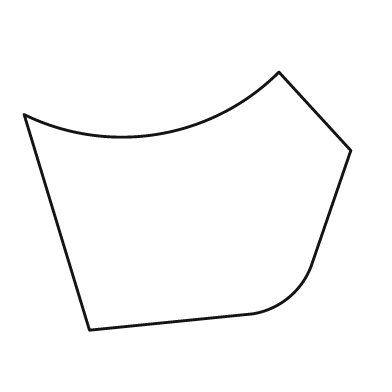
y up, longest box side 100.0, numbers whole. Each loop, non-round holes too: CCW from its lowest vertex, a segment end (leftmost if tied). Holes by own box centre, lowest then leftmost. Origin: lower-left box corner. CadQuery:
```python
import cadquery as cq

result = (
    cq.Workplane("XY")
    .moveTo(20.0, 0.0)
    .lineTo(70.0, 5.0)
    .threePointArc((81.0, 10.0), (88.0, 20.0))
    .lineTo(100.0, 55.0)
    .lineTo(78.0, 79.0)
    .threePointArc((41.0, 60.0), (0.0, 66.0))
    .close()
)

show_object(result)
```